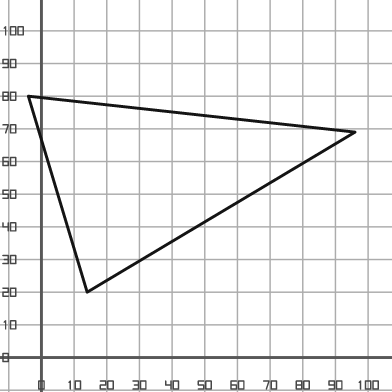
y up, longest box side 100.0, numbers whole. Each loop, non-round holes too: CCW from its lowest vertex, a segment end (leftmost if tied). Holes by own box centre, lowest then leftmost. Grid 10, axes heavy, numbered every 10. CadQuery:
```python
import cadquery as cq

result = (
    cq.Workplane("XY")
    .moveTo(14.0, 20.0)
    .lineTo(96.0, 69.0)
    .lineTo(-4.0, 80.0)
    .close()
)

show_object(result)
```